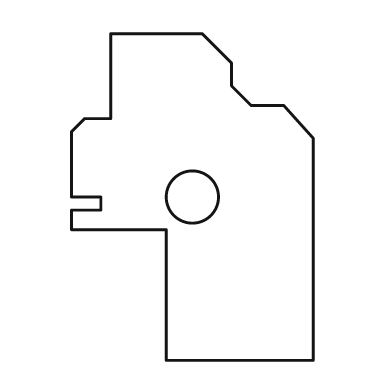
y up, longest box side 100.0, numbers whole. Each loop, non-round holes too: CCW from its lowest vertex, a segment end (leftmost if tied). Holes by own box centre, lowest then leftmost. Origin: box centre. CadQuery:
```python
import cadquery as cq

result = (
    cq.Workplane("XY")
    .moveTo(-8.0, -50.0)
    .lineTo(37.0, -50.0)
    .lineTo(37.0, 18.0)
    .lineTo(28.0, 28.0)
    .lineTo(18.0, 28.0)
    .lineTo(12.0, 34.0)
    .lineTo(12.0, 41.0)
    .lineTo(3.0, 50.0)
    .lineTo(-25.0, 50.0)
    .lineTo(-25.0, 24.0)
    .lineTo(-33.0, 24.0)
    .lineTo(-37.0, 20.0)
    .lineTo(-37.0, 0.0)
    .lineTo(-28.0, 0.0)
    .lineTo(-28.0, -4.0)
    .lineTo(-37.0, -4.0)
    .lineTo(-37.0, -10.0)
    .lineTo(-8.0, -10.0)
    .close()
    .moveTo(0.0, 0.0)
    .circle(8.0)
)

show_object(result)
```